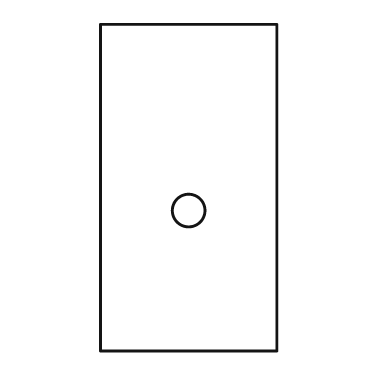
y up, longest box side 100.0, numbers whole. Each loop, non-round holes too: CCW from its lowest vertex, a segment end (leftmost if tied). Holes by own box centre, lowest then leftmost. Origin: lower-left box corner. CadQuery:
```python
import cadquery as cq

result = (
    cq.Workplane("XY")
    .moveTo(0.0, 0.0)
    .lineTo(54.0, 0.0)
    .lineTo(54.0, 100.0)
    .lineTo(0.0, 100.0)
    .close()
    .moveTo(27.0, 43.0)
    .circle(5.0)
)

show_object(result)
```